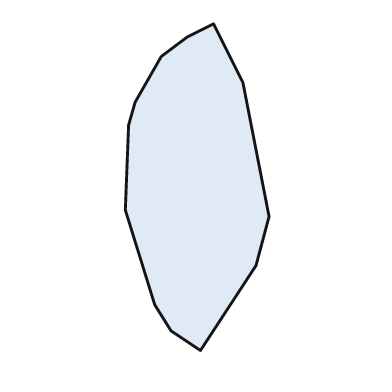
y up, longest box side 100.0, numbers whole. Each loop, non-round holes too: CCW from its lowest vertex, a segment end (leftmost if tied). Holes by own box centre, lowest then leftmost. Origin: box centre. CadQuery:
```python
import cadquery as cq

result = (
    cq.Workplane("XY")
    .moveTo(1.0, -50.0)
    .lineTo(18.0, -24.0)
    .lineTo(22.0, -9.0)
    .lineTo(14.0, 32.0)
    .lineTo(5.0, 50.0)
    .lineTo(-3.0, 46.0)
    .lineTo(-11.0, 40.0)
    .lineTo(-19.0, 26.0)
    .lineTo(-21.0, 19.0)
    .lineTo(-22.0, -7.0)
    .lineTo(-13.0, -36.0)
    .lineTo(-8.0, -44.0)
    .close()
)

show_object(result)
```